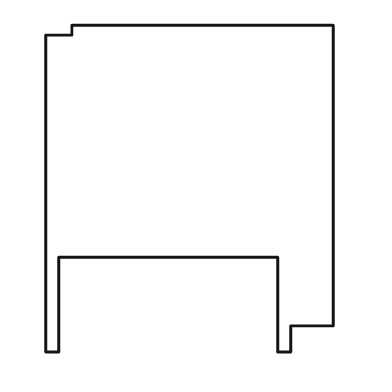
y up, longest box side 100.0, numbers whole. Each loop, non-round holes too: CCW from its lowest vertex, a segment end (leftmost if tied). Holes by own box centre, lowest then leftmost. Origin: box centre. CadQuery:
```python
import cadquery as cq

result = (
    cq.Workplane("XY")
    .moveTo(-44.0, -50.0)
    .lineTo(-40.0, -50.0)
    .lineTo(-40.0, -21.0)
    .lineTo(27.0, -21.0)
    .lineTo(27.0, -50.0)
    .lineTo(31.0, -50.0)
    .lineTo(31.0, -42.0)
    .lineTo(44.0, -42.0)
    .lineTo(44.0, 50.0)
    .lineTo(-36.0, 50.0)
    .lineTo(-36.0, 47.0)
    .lineTo(-44.0, 47.0)
    .close()
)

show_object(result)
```